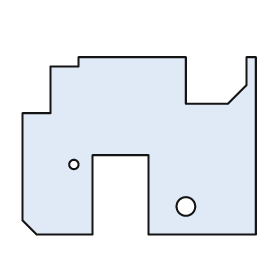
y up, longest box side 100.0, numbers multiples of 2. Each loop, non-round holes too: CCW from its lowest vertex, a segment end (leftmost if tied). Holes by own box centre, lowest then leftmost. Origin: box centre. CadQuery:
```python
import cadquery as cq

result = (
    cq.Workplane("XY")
    .moveTo(-44.0, -38.0)
    .lineTo(-20.0, -38.0)
    .lineTo(-20.0, -4.0)
    .lineTo(4.0, -4.0)
    .lineTo(4.0, -38.0)
    .lineTo(50.0, -38.0)
    .lineTo(50.0, 38.0)
    .lineTo(46.0, 38.0)
    .lineTo(46.0, 26.0)
    .lineTo(38.0, 18.0)
    .lineTo(20.0, 18.0)
    .lineTo(20.0, 38.0)
    .lineTo(-26.0, 38.0)
    .lineTo(-26.0, 34.0)
    .lineTo(-38.0, 34.0)
    .lineTo(-38.0, 14.0)
    .lineTo(-50.0, 14.0)
    .lineTo(-50.0, -32.0)
    .close()
    .moveTo(20.0, -26.0)
    .circle(4.0)
    .moveTo(-28.0, -8.0)
    .circle(2.0)
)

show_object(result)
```